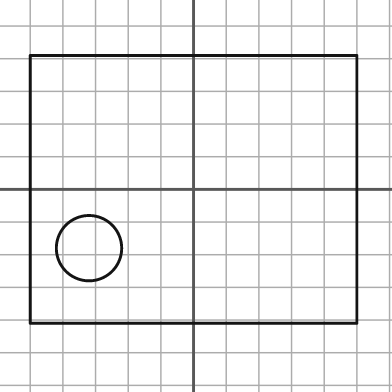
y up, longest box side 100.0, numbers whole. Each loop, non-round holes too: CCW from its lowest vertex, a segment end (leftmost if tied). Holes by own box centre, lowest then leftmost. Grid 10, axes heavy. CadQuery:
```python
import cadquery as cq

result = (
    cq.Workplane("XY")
    .moveTo(-50.0, -41.0)
    .lineTo(50.0, -41.0)
    .lineTo(50.0, 41.0)
    .lineTo(-50.0, 41.0)
    .close()
    .moveTo(-32.0, -18.0)
    .circle(10.0)
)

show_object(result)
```